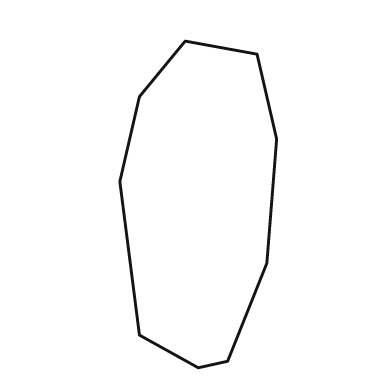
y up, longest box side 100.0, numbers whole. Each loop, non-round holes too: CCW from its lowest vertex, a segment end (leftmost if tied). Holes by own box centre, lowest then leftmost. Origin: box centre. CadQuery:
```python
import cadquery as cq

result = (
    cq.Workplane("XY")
    .moveTo(0.0, -50.0)
    .lineTo(9.0, -48.0)
    .lineTo(21.0, -18.0)
    .lineTo(24.0, 20.0)
    .lineTo(18.0, 46.0)
    .lineTo(-4.0, 50.0)
    .lineTo(-18.0, 33.0)
    .lineTo(-24.0, 7.0)
    .lineTo(-18.0, -40.0)
    .close()
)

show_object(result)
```